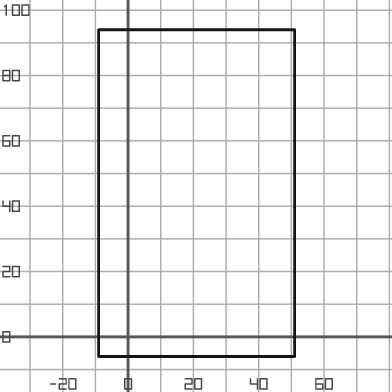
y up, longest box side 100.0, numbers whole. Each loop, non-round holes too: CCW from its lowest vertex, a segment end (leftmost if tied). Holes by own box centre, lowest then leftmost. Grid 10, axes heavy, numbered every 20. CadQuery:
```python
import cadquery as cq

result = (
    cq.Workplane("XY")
    .moveTo(-9.0, -6.0)
    .lineTo(51.0, -6.0)
    .lineTo(51.0, 94.0)
    .lineTo(-9.0, 94.0)
    .close()
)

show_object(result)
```